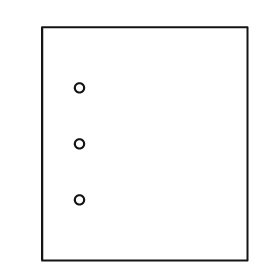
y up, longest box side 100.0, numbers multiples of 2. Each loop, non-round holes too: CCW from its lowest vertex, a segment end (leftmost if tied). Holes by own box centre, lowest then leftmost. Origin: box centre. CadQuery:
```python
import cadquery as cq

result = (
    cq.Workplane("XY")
    .moveTo(-44.0, -50.0)
    .lineTo(44.0, -50.0)
    .lineTo(44.0, 50.0)
    .lineTo(-44.0, 50.0)
    .close()
    .moveTo(-28.0, -24.0)
    .circle(2.0)
    .moveTo(-28.0, 0.0)
    .circle(2.0)
    .moveTo(-28.0, 24.0)
    .circle(2.0)
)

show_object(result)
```